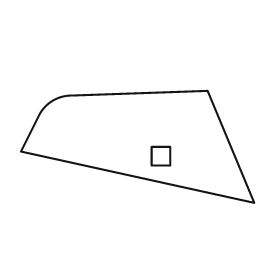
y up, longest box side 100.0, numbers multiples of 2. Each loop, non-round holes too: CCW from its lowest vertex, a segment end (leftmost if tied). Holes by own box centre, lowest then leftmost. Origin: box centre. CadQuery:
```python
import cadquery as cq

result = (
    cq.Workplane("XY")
    .moveTo(50.0, -24.0)
    .lineTo(30.0, 24.0)
    .lineTo(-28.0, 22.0)
    .threePointArc((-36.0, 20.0), (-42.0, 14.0))
    .lineTo(-50.0, -2.0)
    .close()
    .moveTo(6.0, -8.0)
    .lineTo(14.0, -8.0)
    .lineTo(14.0, 0.0)
    .lineTo(6.0, 0.0)
    .close()
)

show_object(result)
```